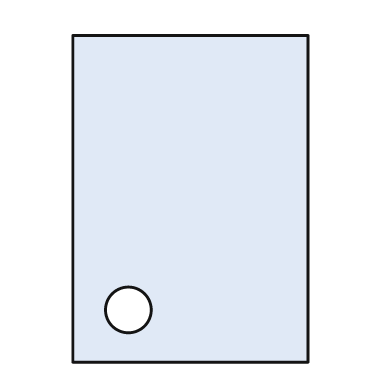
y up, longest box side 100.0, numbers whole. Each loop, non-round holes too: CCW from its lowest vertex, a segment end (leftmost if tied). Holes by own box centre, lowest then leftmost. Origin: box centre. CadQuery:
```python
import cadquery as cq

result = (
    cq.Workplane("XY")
    .moveTo(-36.0, -50.0)
    .lineTo(36.0, -50.0)
    .lineTo(36.0, 50.0)
    .lineTo(-36.0, 50.0)
    .close()
    .moveTo(-19.0, -34.0)
    .circle(7.0)
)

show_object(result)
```